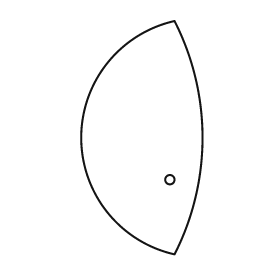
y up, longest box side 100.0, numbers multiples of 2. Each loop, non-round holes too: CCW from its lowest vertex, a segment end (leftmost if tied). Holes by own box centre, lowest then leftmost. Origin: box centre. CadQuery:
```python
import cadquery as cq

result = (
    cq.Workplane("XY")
    .moveTo(14.0, -50.0)
    .threePointArc((26.0, 0.0), (14.0, 50.0))
    .threePointArc((-26.0, 0.0), (14.0, -50.0))
    .close()
    .moveTo(12.0, -18.0)
    .circle(2.0)
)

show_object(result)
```